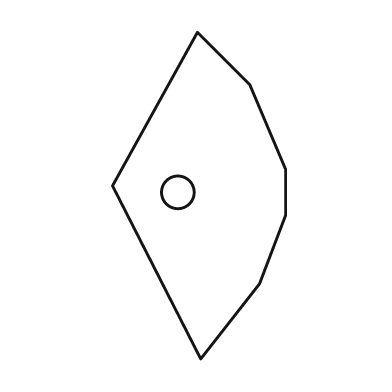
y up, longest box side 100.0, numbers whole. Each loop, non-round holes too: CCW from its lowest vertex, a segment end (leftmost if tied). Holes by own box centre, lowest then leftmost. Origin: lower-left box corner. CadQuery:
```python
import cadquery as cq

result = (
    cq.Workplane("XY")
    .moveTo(27.0, 0.0)
    .lineTo(45.0, 23.0)
    .lineTo(53.0, 44.0)
    .lineTo(53.0, 58.0)
    .lineTo(42.0, 84.0)
    .lineTo(26.0, 100.0)
    .lineTo(0.0, 53.0)
    .close()
    .moveTo(20.0, 51.0)
    .circle(5.0)
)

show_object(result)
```